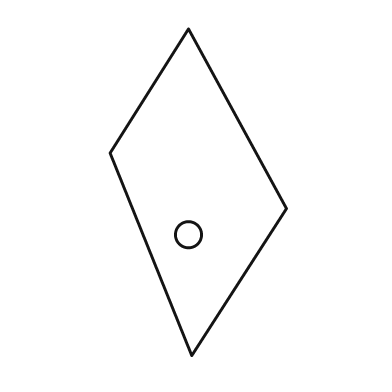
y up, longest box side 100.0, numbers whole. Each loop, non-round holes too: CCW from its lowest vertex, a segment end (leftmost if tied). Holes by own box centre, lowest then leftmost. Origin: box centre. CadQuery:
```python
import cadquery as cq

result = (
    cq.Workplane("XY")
    .moveTo(-2.0, -50.0)
    .lineTo(27.0, -5.0)
    .lineTo(-3.0, 50.0)
    .lineTo(-27.0, 12.0)
    .close()
    .moveTo(-3.0, -13.0)
    .circle(4.0)
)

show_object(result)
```